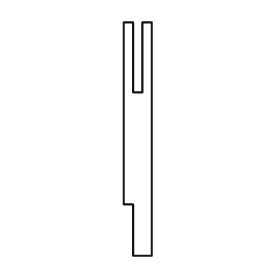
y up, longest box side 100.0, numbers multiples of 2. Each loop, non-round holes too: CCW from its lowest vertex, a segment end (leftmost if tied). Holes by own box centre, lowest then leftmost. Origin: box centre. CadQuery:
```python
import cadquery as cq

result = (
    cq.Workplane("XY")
    .moveTo(-2.0, -50.0)
    .lineTo(6.0, -50.0)
    .lineTo(6.0, 50.0)
    .lineTo(2.0, 50.0)
    .lineTo(2.0, 20.0)
    .lineTo(-2.0, 20.0)
    .lineTo(-2.0, 50.0)
    .lineTo(-6.0, 50.0)
    .lineTo(-6.0, -28.0)
    .lineTo(-2.0, -28.0)
    .close()
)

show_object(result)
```